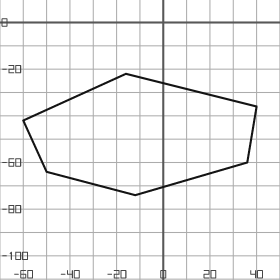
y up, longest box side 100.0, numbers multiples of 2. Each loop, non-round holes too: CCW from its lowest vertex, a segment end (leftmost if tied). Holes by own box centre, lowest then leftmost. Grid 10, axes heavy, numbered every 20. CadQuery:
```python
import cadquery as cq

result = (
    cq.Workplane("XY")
    .moveTo(-12.0, -74.0)
    .lineTo(36.0, -60.0)
    .lineTo(40.0, -36.0)
    .lineTo(-16.0, -22.0)
    .lineTo(-60.0, -42.0)
    .lineTo(-50.0, -64.0)
    .close()
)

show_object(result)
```